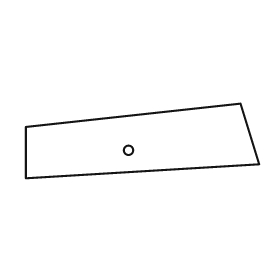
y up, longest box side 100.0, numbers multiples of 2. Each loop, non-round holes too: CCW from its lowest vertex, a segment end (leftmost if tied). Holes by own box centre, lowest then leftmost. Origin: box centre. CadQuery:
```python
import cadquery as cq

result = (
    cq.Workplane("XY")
    .moveTo(-50.0, -16.0)
    .lineTo(50.0, -10.0)
    .lineTo(42.0, 16.0)
    .lineTo(-50.0, 6.0)
    .close()
    .moveTo(-6.0, -4.0)
    .circle(2.0)
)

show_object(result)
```